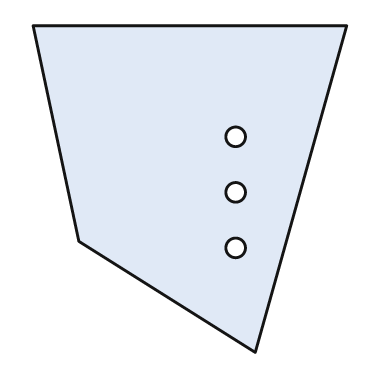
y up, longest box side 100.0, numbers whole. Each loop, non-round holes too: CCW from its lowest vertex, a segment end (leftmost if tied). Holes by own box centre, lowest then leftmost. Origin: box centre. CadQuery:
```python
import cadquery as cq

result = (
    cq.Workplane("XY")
    .moveTo(20.0, -50.0)
    .lineTo(48.0, 50.0)
    .lineTo(-48.0, 50.0)
    .lineTo(-34.0, -16.0)
    .close()
    .moveTo(14.0, -18.0)
    .circle(3.0)
    .moveTo(14.0, -1.0)
    .circle(3.0)
    .moveTo(14.0, 16.0)
    .circle(3.0)
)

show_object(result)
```